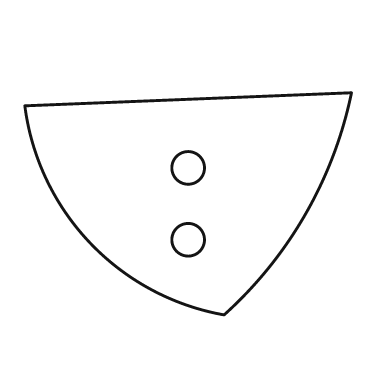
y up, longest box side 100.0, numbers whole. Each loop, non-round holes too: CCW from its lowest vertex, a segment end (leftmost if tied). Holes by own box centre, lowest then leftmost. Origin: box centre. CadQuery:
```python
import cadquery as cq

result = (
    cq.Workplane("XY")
    .moveTo(11.0, -34.0)
    .threePointArc((36.0, -3.0), (50.0, 34.0))
    .lineTo(-50.0, 30.0)
    .threePointArc((-30.0, -12.0), (11.0, -34.0))
    .close()
    .moveTo(0.0, -11.0)
    .circle(5.0)
    .moveTo(0.0, 11.0)
    .circle(5.0)
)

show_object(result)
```